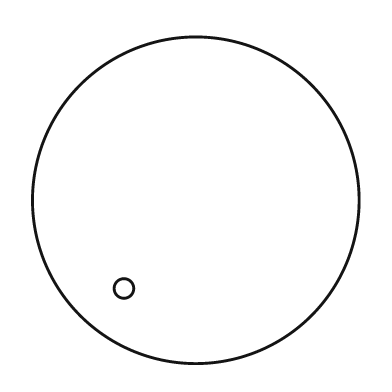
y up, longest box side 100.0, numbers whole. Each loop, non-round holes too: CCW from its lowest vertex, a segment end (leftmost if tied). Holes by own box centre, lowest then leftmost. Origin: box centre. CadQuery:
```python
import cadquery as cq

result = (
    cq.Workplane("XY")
    .moveTo(0.0, 0.0)
    .circle(50.0)
    .moveTo(-22.0, -27.0)
    .circle(3.0)
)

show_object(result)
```